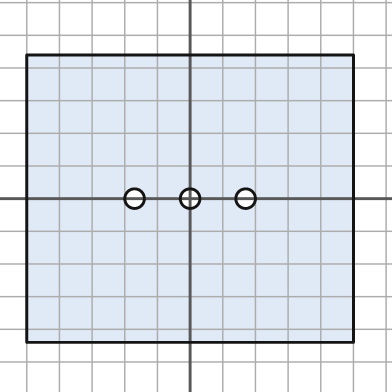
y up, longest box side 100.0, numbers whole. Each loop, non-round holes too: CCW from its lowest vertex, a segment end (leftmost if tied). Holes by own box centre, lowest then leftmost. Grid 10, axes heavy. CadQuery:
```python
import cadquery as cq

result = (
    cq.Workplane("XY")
    .moveTo(-50.0, -44.0)
    .lineTo(50.0, -44.0)
    .lineTo(50.0, 44.0)
    .lineTo(-50.0, 44.0)
    .close()
    .moveTo(-17.0, 0.0)
    .circle(3.0)
    .moveTo(0.0, 0.0)
    .circle(3.0)
    .moveTo(17.0, 0.0)
    .circle(3.0)
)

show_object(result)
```